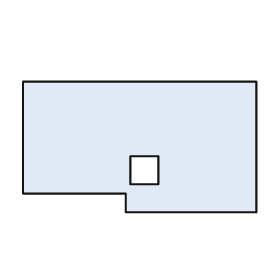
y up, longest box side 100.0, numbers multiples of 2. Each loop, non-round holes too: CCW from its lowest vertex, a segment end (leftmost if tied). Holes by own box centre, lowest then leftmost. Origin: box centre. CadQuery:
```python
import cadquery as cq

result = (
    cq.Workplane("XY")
    .moveTo(-6.0, -28.0)
    .lineTo(50.0, -28.0)
    .lineTo(50.0, 28.0)
    .lineTo(-50.0, 28.0)
    .lineTo(-50.0, -20.0)
    .lineTo(-6.0, -20.0)
    .close()
    .moveTo(-4.0, -16.0)
    .lineTo(8.0, -16.0)
    .lineTo(8.0, -4.0)
    .lineTo(-4.0, -4.0)
    .close()
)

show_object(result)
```